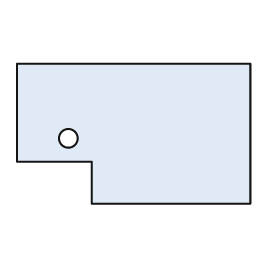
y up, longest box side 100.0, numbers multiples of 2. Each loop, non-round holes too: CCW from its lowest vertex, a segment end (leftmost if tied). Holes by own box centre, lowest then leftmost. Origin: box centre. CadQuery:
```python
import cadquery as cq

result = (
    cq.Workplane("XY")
    .moveTo(-18.0, -30.0)
    .lineTo(50.0, -30.0)
    .lineTo(50.0, 30.0)
    .lineTo(-50.0, 30.0)
    .lineTo(-50.0, -12.0)
    .lineTo(-18.0, -12.0)
    .close()
    .moveTo(-28.0, -2.0)
    .circle(4.0)
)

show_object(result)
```